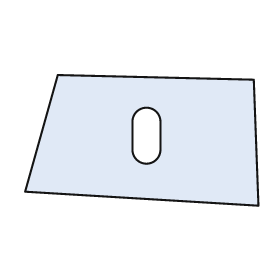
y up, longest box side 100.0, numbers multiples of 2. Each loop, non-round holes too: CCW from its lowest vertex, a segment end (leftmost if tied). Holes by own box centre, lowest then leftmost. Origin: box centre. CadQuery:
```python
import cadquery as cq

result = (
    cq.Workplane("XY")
    .moveTo(50.0, -28.0)
    .lineTo(48.0, 26.0)
    .lineTo(-36.0, 28.0)
    .lineTo(-50.0, -22.0)
    .close()
    .moveTo(-4.0, -4.0)
    .threePointArc((2.0, -10.0), (8.0, -4.0))
    .lineTo(8.0, 8.0)
    .threePointArc((2.0, 14.0), (-4.0, 8.0))
    .close()
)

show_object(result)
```